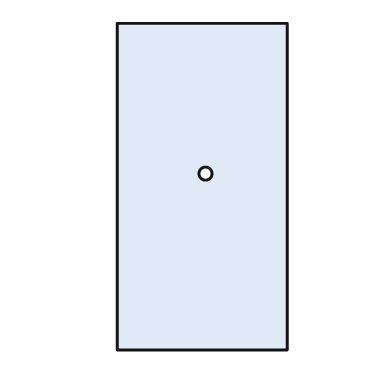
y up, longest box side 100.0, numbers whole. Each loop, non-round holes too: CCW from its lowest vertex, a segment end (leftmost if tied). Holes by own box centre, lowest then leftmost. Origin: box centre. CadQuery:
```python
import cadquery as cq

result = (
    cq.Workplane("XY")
    .moveTo(-26.0, -50.0)
    .lineTo(26.0, -50.0)
    .lineTo(26.0, 50.0)
    .lineTo(-26.0, 50.0)
    .close()
    .moveTo(1.0, 4.0)
    .circle(2.0)
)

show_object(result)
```